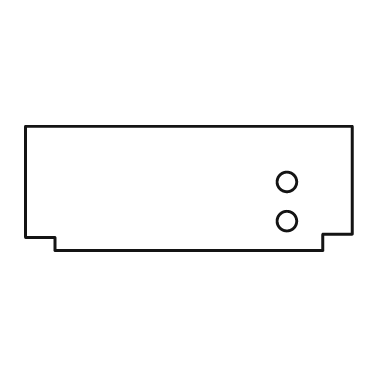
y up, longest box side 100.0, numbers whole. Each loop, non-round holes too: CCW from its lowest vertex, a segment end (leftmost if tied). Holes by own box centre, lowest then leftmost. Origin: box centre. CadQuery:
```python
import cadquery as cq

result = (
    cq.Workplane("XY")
    .moveTo(-41.0, -19.0)
    .lineTo(41.0, -19.0)
    .lineTo(41.0, -14.0)
    .lineTo(50.0, -14.0)
    .lineTo(50.0, 19.0)
    .lineTo(-50.0, 19.0)
    .lineTo(-50.0, -15.0)
    .lineTo(-41.0, -15.0)
    .close()
    .moveTo(30.0, -10.0)
    .circle(3.0)
    .moveTo(30.0, 2.0)
    .circle(3.0)
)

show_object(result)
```